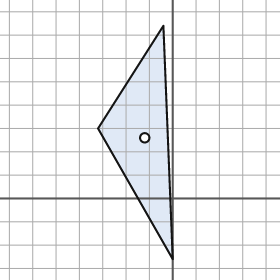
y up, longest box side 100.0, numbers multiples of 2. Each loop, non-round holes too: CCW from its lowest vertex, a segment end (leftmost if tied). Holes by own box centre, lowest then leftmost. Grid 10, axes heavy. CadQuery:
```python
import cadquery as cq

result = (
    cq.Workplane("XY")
    .moveTo(0.0, -26.0)
    .lineTo(-4.0, 74.0)
    .lineTo(-32.0, 30.0)
    .close()
    .moveTo(-12.0, 26.0)
    .circle(2.0)
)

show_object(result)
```